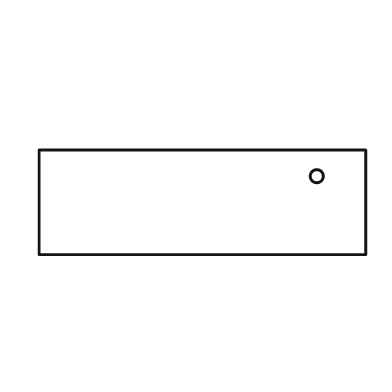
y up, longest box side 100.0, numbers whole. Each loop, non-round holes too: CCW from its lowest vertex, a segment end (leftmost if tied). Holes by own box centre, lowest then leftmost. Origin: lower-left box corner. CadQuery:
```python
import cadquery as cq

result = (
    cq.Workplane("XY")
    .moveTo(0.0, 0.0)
    .lineTo(100.0, 0.0)
    .lineTo(100.0, 32.0)
    .lineTo(0.0, 32.0)
    .close()
    .moveTo(85.0, 24.0)
    .circle(2.0)
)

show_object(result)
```